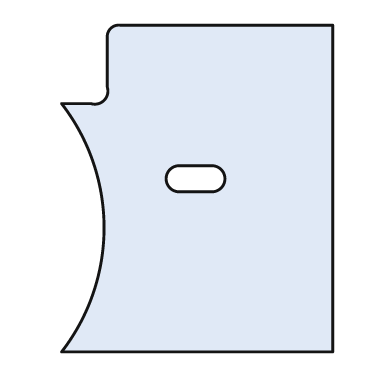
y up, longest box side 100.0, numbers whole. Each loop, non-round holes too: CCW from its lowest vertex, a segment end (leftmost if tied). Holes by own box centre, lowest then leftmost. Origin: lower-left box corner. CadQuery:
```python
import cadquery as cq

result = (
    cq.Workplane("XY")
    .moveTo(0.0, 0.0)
    .lineTo(83.0, 0.0)
    .lineTo(83.0, 100.0)
    .lineTo(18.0, 100.0)
    .threePointArc((15.0, 99.0), (14.0, 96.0))
    .lineTo(14.0, 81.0)
    .threePointArc((13.0, 77.0), (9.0, 76.0))
    .lineTo(0.0, 76.0)
    .threePointArc((13.0, 38.0), (0.0, 0.0))
    .close()
    .moveTo(36.0, 49.0)
    .lineTo(46.0, 49.0)
    .threePointArc((50.0, 53.0), (46.0, 57.0))
    .lineTo(36.0, 57.0)
    .threePointArc((32.0, 53.0), (36.0, 49.0))
    .close()
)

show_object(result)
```